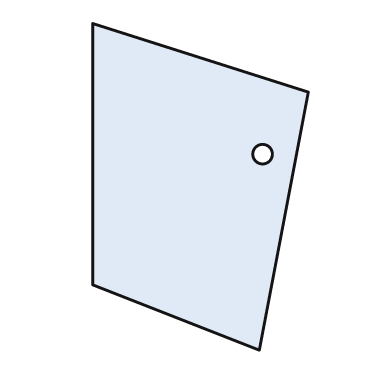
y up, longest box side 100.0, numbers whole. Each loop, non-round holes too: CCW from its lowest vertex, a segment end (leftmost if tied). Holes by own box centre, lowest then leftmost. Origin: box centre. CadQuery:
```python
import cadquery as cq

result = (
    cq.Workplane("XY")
    .moveTo(18.0, -50.0)
    .lineTo(33.0, 29.0)
    .lineTo(-33.0, 50.0)
    .lineTo(-33.0, -30.0)
    .close()
    .moveTo(19.0, 10.0)
    .circle(3.0)
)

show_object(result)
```